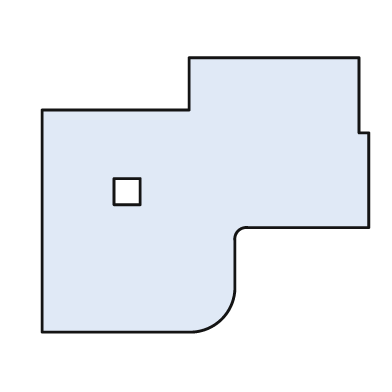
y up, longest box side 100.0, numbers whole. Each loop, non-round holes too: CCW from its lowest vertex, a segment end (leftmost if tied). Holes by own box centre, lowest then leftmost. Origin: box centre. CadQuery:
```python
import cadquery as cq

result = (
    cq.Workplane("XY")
    .moveTo(-50.0, -42.0)
    .lineTo(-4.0, -42.0)
    .threePointArc((5.0, -38.0), (9.0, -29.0))
    .lineTo(9.0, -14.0)
    .threePointArc((10.0, -11.0), (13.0, -10.0))
    .lineTo(50.0, -10.0)
    .lineTo(50.0, 19.0)
    .lineTo(47.0, 19.0)
    .lineTo(47.0, 42.0)
    .lineTo(-5.0, 42.0)
    .lineTo(-5.0, 26.0)
    .lineTo(-50.0, 26.0)
    .close()
    .moveTo(-28.0, -3.0)
    .lineTo(-20.0, -3.0)
    .lineTo(-20.0, 5.0)
    .lineTo(-28.0, 5.0)
    .close()
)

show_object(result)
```